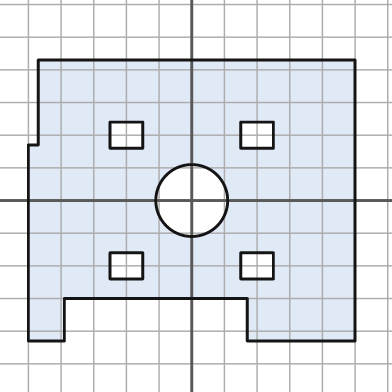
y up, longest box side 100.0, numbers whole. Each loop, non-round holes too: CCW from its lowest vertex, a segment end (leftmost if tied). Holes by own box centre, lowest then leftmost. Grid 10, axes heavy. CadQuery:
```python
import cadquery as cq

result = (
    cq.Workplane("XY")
    .moveTo(-50.0, -43.0)
    .lineTo(-39.0, -43.0)
    .lineTo(-39.0, -30.0)
    .lineTo(17.0, -30.0)
    .lineTo(17.0, -43.0)
    .lineTo(50.0, -43.0)
    .lineTo(50.0, 43.0)
    .lineTo(-47.0, 43.0)
    .lineTo(-47.0, 17.0)
    .lineTo(-50.0, 17.0)
    .close()
    .moveTo(-25.0, -24.0)
    .lineTo(-15.0, -24.0)
    .lineTo(-15.0, -16.0)
    .lineTo(-25.0, -16.0)
    .close()
    .moveTo(15.0, -24.0)
    .lineTo(25.0, -24.0)
    .lineTo(25.0, -16.0)
    .lineTo(15.0, -16.0)
    .close()
    .moveTo(0.0, 0.0)
    .circle(11.0)
    .moveTo(-25.0, 16.0)
    .lineTo(-15.0, 16.0)
    .lineTo(-15.0, 24.0)
    .lineTo(-25.0, 24.0)
    .close()
    .moveTo(15.0, 16.0)
    .lineTo(25.0, 16.0)
    .lineTo(25.0, 24.0)
    .lineTo(15.0, 24.0)
    .close()
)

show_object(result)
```